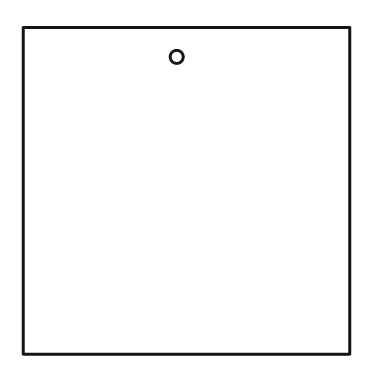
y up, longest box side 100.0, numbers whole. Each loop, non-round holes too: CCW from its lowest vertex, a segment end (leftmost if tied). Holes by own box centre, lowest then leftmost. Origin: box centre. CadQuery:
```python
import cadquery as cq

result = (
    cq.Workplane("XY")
    .moveTo(-50.0, -50.0)
    .lineTo(50.0, -50.0)
    .lineTo(50.0, 50.0)
    .lineTo(-50.0, 50.0)
    .close()
    .moveTo(-3.0, 41.0)
    .circle(2.0)
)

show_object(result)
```